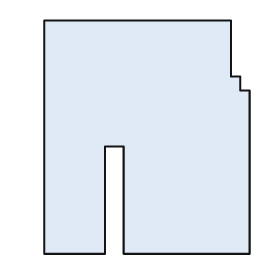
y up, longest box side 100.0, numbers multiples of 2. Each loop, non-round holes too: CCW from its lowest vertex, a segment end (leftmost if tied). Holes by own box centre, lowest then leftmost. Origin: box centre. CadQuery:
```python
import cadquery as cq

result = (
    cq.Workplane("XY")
    .moveTo(-44.0, -50.0)
    .lineTo(-18.0, -50.0)
    .lineTo(-18.0, -4.0)
    .lineTo(-10.0, -4.0)
    .lineTo(-10.0, -50.0)
    .lineTo(44.0, -50.0)
    .lineTo(44.0, 20.0)
    .lineTo(40.0, 20.0)
    .lineTo(40.0, 26.0)
    .lineTo(36.0, 26.0)
    .lineTo(36.0, 50.0)
    .lineTo(-44.0, 50.0)
    .close()
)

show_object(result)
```